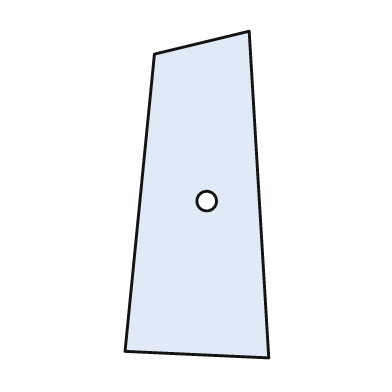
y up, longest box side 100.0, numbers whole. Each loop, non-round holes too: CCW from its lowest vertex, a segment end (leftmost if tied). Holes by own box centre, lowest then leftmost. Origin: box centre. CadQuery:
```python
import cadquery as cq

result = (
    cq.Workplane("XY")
    .moveTo(22.0, -50.0)
    .lineTo(16.0, 50.0)
    .lineTo(-13.0, 43.0)
    .lineTo(-22.0, -48.0)
    .close()
    .moveTo(3.0, -2.0)
    .circle(3.0)
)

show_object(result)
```